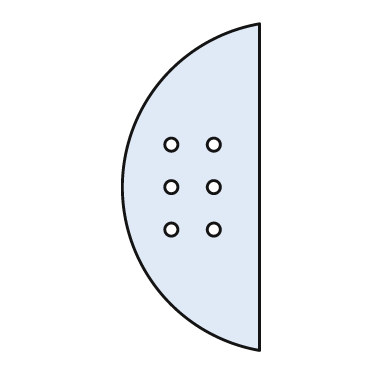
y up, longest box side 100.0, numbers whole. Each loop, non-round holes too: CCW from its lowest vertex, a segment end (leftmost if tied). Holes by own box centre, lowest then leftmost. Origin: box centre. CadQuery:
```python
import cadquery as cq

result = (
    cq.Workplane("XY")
    .moveTo(21.0, -50.0)
    .lineTo(21.0, 50.0)
    .threePointArc((-21.0, 0.0), (21.0, -50.0))
    .close()
    .moveTo(-6.0, -13.0)
    .circle(2.0)
    .moveTo(7.0, -13.0)
    .circle(2.0)
    .moveTo(-6.0, 0.0)
    .circle(2.0)
    .moveTo(7.0, 0.0)
    .circle(2.0)
    .moveTo(-6.0, 13.0)
    .circle(2.0)
    .moveTo(7.0, 13.0)
    .circle(2.0)
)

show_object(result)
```